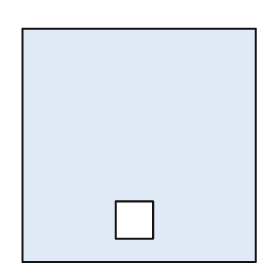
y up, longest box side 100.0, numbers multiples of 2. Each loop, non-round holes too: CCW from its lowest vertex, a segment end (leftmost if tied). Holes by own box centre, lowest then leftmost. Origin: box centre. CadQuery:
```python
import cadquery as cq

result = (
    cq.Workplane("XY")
    .moveTo(-50.0, -50.0)
    .lineTo(50.0, -50.0)
    .lineTo(50.0, 50.0)
    .lineTo(-50.0, 50.0)
    .close()
    .moveTo(-10.0, -40.0)
    .lineTo(6.0, -40.0)
    .lineTo(6.0, -24.0)
    .lineTo(-10.0, -24.0)
    .close()
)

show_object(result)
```